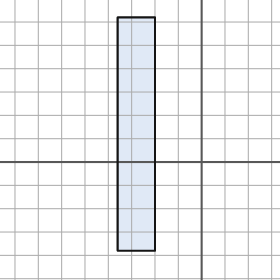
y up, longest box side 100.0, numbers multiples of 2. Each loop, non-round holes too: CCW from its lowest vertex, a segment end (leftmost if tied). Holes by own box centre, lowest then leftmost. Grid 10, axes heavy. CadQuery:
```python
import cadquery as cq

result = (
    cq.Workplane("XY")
    .moveTo(-36.0, -38.0)
    .lineTo(-20.0, -38.0)
    .lineTo(-20.0, 62.0)
    .lineTo(-36.0, 62.0)
    .close()
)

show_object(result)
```